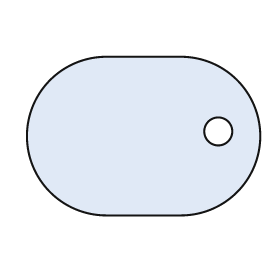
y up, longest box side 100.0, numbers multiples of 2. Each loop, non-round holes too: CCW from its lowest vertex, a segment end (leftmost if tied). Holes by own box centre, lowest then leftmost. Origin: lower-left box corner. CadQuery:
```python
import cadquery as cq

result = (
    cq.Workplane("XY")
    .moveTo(34.0, 0.0)
    .lineTo(66.0, 0.0)
    .threePointArc((100.0, 34.0), (66.0, 68.0))
    .lineTo(34.0, 68.0)
    .threePointArc((0.0, 34.0), (34.0, 0.0))
    .close()
    .moveTo(82.0, 36.0)
    .circle(6.0)
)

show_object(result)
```